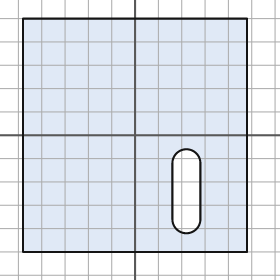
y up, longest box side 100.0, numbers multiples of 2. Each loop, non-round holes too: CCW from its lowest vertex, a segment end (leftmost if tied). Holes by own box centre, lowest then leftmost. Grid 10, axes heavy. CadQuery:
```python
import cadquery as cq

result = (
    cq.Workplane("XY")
    .moveTo(-48.0, -50.0)
    .lineTo(48.0, -50.0)
    .lineTo(48.0, 50.0)
    .lineTo(-48.0, 50.0)
    .close()
    .moveTo(16.0, -36.0)
    .threePointArc((22.0, -42.0), (28.0, -36.0))
    .lineTo(28.0, -12.0)
    .threePointArc((22.0, -6.0), (16.0, -12.0))
    .close()
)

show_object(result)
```